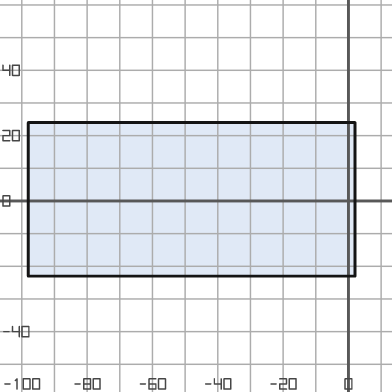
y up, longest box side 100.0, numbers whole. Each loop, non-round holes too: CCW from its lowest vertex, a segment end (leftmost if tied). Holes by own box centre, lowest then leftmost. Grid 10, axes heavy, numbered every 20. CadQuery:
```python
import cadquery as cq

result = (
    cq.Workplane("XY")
    .moveTo(-98.0, -23.0)
    .lineTo(2.0, -23.0)
    .lineTo(2.0, 24.0)
    .lineTo(-98.0, 24.0)
    .close()
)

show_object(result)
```